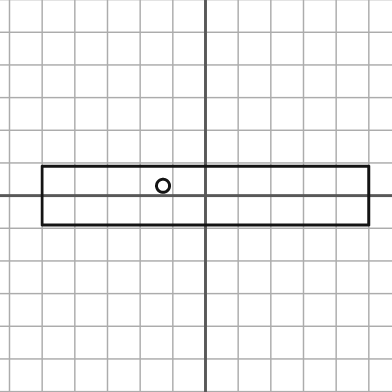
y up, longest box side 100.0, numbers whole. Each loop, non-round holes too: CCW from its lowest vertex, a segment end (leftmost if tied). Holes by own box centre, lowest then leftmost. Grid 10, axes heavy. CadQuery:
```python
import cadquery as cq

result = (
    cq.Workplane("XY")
    .moveTo(-50.0, -9.0)
    .lineTo(50.0, -9.0)
    .lineTo(50.0, 9.0)
    .lineTo(-50.0, 9.0)
    .close()
    .moveTo(-13.0, 3.0)
    .circle(2.0)
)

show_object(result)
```